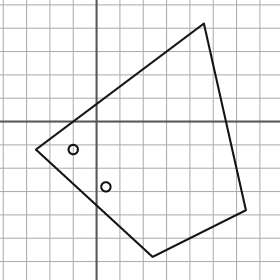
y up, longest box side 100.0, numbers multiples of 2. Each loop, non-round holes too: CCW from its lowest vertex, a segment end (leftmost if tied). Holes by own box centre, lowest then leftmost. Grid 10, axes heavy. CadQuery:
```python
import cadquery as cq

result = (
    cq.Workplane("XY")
    .moveTo(24.0, -58.0)
    .lineTo(64.0, -38.0)
    .lineTo(46.0, 42.0)
    .lineTo(-26.0, -12.0)
    .close()
    .moveTo(4.0, -28.0)
    .circle(2.0)
    .moveTo(-10.0, -12.0)
    .circle(2.0)
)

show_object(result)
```